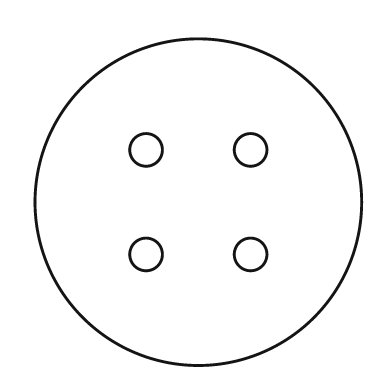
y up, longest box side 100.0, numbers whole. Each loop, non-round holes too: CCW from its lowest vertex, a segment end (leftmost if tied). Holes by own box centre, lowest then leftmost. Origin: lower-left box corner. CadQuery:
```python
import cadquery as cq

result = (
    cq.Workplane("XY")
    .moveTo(50.0, 50.0)
    .circle(50.0)
    .moveTo(34.0, 34.0)
    .circle(5.0)
    .moveTo(66.0, 34.0)
    .circle(5.0)
    .moveTo(34.0, 66.0)
    .circle(5.0)
    .moveTo(66.0, 66.0)
    .circle(5.0)
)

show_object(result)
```